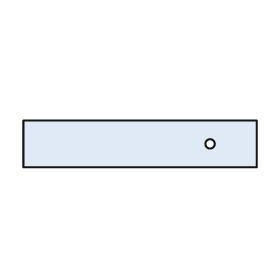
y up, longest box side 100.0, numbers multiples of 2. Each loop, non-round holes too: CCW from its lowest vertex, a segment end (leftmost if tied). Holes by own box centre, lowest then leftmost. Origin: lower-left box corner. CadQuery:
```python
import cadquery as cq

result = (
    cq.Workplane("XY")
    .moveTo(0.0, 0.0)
    .lineTo(100.0, 0.0)
    .lineTo(100.0, 20.0)
    .lineTo(0.0, 20.0)
    .close()
    .moveTo(80.0, 10.0)
    .circle(2.0)
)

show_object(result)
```